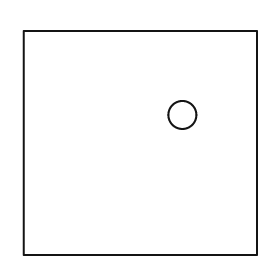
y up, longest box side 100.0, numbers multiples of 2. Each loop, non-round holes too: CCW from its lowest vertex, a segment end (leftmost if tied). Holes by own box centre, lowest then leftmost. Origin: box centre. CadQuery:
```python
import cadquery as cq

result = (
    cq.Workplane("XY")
    .moveTo(-50.0, -48.0)
    .lineTo(50.0, -48.0)
    .lineTo(50.0, 48.0)
    .lineTo(-50.0, 48.0)
    .close()
    .moveTo(18.0, 12.0)
    .circle(6.0)
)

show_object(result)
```